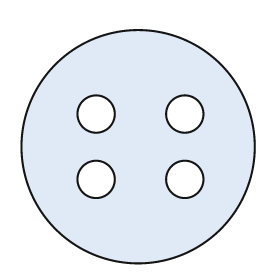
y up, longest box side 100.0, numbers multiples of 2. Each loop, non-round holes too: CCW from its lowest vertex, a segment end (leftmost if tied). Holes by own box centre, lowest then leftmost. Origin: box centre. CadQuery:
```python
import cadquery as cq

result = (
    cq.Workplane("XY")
    .moveTo(0.0, 0.0)
    .circle(50.0)
    .moveTo(-18.0, -14.0)
    .circle(8.0)
    .moveTo(20.0, -14.0)
    .circle(8.0)
    .moveTo(-18.0, 14.0)
    .circle(8.0)
    .moveTo(20.0, 14.0)
    .circle(8.0)
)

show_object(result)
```